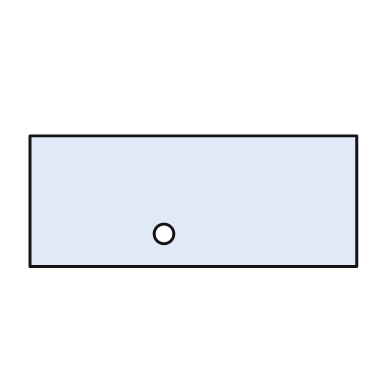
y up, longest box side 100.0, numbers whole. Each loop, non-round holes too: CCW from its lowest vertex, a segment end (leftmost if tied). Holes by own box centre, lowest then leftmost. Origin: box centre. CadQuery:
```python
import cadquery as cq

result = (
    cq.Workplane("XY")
    .moveTo(-50.0, -20.0)
    .lineTo(50.0, -20.0)
    .lineTo(50.0, 20.0)
    .lineTo(-50.0, 20.0)
    .close()
    .moveTo(-9.0, -10.0)
    .circle(3.0)
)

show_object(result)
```